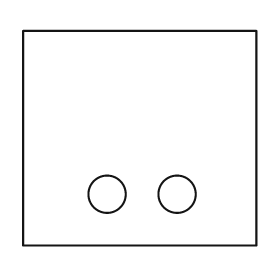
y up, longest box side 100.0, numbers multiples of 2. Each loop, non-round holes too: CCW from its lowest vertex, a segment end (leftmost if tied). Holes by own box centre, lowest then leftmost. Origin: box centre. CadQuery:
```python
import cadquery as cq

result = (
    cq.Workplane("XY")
    .moveTo(-50.0, -46.0)
    .lineTo(50.0, -46.0)
    .lineTo(50.0, 46.0)
    .lineTo(-50.0, 46.0)
    .close()
    .moveTo(-14.0, -24.0)
    .circle(8.0)
    .moveTo(16.0, -24.0)
    .circle(8.0)
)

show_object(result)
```